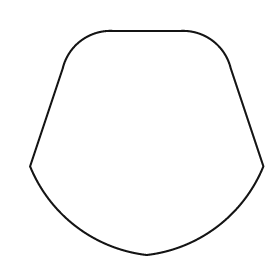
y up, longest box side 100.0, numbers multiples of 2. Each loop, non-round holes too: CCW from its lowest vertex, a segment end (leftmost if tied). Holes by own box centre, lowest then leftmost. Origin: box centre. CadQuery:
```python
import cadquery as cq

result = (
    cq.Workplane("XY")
    .moveTo(0.0, -48.0)
    .threePointArc((30.0, -36.0), (50.0, -10.0))
    .lineTo(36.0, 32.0)
    .threePointArc((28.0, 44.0), (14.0, 48.0))
    .lineTo(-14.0, 48.0)
    .threePointArc((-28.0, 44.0), (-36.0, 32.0))
    .lineTo(-50.0, -10.0)
    .threePointArc((-30.0, -36.0), (0.0, -48.0))
    .close()
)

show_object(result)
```